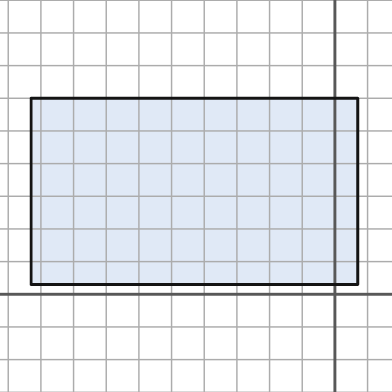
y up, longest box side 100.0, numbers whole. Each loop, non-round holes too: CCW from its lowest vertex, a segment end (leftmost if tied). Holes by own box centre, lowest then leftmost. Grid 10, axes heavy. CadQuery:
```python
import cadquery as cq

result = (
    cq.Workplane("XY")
    .moveTo(-93.0, 3.0)
    .lineTo(7.0, 3.0)
    .lineTo(7.0, 60.0)
    .lineTo(-93.0, 60.0)
    .close()
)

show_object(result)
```